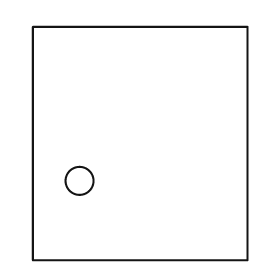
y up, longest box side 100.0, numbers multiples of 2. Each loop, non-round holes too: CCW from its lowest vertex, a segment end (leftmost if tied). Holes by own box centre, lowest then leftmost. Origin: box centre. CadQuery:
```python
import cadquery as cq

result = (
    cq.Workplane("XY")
    .moveTo(-46.0, -50.0)
    .lineTo(46.0, -50.0)
    .lineTo(46.0, 50.0)
    .lineTo(-46.0, 50.0)
    .close()
    .moveTo(-26.0, -16.0)
    .circle(6.0)
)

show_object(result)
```